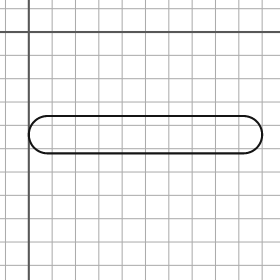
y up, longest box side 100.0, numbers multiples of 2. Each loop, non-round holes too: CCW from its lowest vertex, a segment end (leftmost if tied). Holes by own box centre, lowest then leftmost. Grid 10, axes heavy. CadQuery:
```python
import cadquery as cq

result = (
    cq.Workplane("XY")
    .moveTo(8.0, -52.0)
    .lineTo(92.0, -52.0)
    .threePointArc((100.0, -44.0), (92.0, -36.0))
    .lineTo(8.0, -36.0)
    .threePointArc((0.0, -44.0), (8.0, -52.0))
    .close()
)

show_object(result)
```